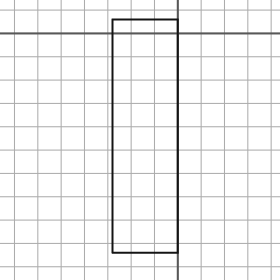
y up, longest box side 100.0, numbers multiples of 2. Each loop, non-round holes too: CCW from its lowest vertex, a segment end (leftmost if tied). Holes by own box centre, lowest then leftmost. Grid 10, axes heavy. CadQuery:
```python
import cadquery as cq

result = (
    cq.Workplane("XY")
    .moveTo(-28.0, -94.0)
    .lineTo(0.0, -94.0)
    .lineTo(0.0, 6.0)
    .lineTo(-28.0, 6.0)
    .close()
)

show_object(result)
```